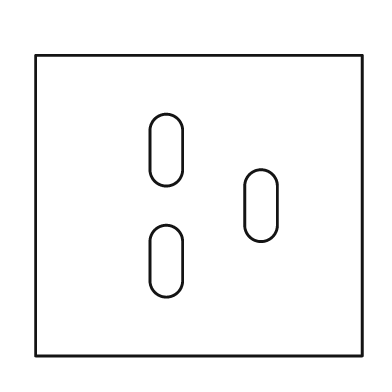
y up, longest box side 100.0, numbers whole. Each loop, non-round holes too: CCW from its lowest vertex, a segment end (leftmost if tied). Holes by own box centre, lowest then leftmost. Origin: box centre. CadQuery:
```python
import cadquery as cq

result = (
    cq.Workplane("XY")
    .moveTo(-50.0, -46.0)
    .lineTo(50.0, -46.0)
    .lineTo(50.0, 46.0)
    .lineTo(-50.0, 46.0)
    .close()
    .moveTo(-15.0, -23.0)
    .threePointArc((-10.0, -28.0), (-5.0, -23.0))
    .lineTo(-5.0, -11.0)
    .threePointArc((-10.0, -6.0), (-15.0, -11.0))
    .close()
    .moveTo(14.0, -6.0)
    .threePointArc((19.0, -11.0), (24.0, -6.0))
    .lineTo(24.0, 6.0)
    .threePointArc((19.0, 11.0), (14.0, 6.0))
    .close()
    .moveTo(-15.0, 11.0)
    .threePointArc((-10.0, 6.0), (-5.0, 11.0))
    .lineTo(-5.0, 23.0)
    .threePointArc((-10.0, 28.0), (-15.0, 23.0))
    .close()
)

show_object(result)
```